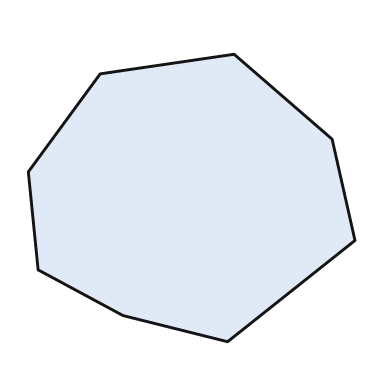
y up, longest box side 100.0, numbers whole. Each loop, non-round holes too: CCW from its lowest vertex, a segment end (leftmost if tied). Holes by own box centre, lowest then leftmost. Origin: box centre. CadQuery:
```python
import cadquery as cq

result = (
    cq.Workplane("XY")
    .moveTo(11.0, -44.0)
    .lineTo(50.0, -13.0)
    .lineTo(43.0, 18.0)
    .lineTo(13.0, 44.0)
    .lineTo(-28.0, 38.0)
    .lineTo(-50.0, 8.0)
    .lineTo(-47.0, -22.0)
    .lineTo(-21.0, -36.0)
    .close()
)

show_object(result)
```